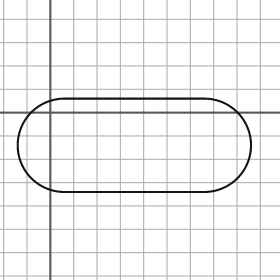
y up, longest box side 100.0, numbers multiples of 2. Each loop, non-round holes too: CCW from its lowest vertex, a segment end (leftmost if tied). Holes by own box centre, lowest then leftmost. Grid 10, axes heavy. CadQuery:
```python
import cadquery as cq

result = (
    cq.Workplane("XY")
    .moveTo(6.0, -34.0)
    .lineTo(66.0, -34.0)
    .threePointArc((86.0, -14.0), (66.0, 6.0))
    .lineTo(6.0, 6.0)
    .threePointArc((-14.0, -14.0), (6.0, -34.0))
    .close()
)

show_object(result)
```